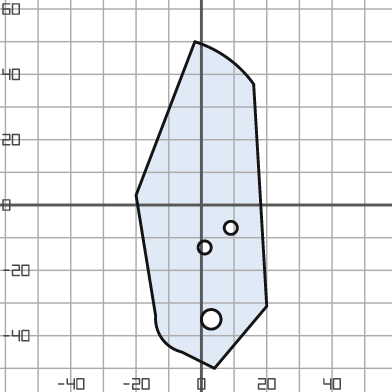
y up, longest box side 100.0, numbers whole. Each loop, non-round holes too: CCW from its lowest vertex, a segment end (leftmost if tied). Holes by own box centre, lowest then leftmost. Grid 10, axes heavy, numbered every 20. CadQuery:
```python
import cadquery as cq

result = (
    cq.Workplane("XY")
    .moveTo(4.0, -50.0)
    .lineTo(20.0, -31.0)
    .lineTo(16.0, 37.0)
    .threePointArc((8.0, 45.0), (-2.0, 50.0))
    .lineTo(-20.0, 3.0)
    .lineTo(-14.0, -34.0)
    .threePointArc((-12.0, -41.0), (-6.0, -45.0))
    .close()
    .moveTo(3.0, -35.0)
    .circle(3.0)
    .moveTo(1.0, -13.0)
    .circle(2.0)
    .moveTo(9.0, -7.0)
    .circle(2.0)
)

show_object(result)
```